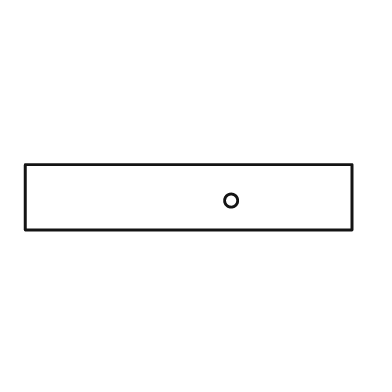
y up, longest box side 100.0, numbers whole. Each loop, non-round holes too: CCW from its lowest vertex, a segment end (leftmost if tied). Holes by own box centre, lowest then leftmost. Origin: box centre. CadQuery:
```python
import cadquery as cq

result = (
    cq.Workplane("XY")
    .moveTo(-50.0, -10.0)
    .lineTo(50.0, -10.0)
    .lineTo(50.0, 10.0)
    .lineTo(-50.0, 10.0)
    .close()
    .moveTo(13.0, -1.0)
    .circle(2.0)
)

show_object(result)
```